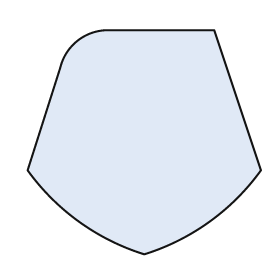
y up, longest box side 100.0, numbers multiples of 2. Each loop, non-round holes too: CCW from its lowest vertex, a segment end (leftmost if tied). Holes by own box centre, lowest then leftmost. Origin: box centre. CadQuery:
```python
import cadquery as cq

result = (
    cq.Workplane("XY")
    .moveTo(0.0, -48.0)
    .threePointArc((28.0, -34.0), (50.0, -12.0))
    .lineTo(30.0, 48.0)
    .lineTo(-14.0, 48.0)
    .threePointArc((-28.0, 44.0), (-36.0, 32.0))
    .lineTo(-50.0, -12.0)
    .threePointArc((-28.0, -34.0), (0.0, -48.0))
    .close()
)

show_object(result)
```